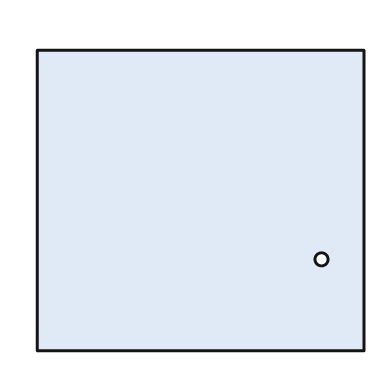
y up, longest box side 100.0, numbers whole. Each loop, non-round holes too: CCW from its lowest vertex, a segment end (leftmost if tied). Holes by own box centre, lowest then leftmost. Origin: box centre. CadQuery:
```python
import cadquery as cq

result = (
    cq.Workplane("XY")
    .moveTo(-50.0, -46.0)
    .lineTo(50.0, -46.0)
    .lineTo(50.0, 46.0)
    .lineTo(-50.0, 46.0)
    .close()
    .moveTo(37.0, -18.0)
    .circle(2.0)
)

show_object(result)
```